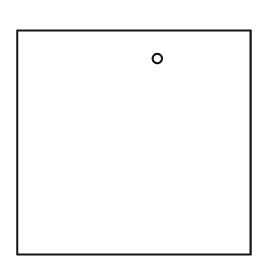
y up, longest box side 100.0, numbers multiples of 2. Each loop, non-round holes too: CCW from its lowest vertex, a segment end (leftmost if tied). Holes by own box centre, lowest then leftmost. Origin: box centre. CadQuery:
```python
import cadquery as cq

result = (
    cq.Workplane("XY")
    .moveTo(-50.0, -48.0)
    .lineTo(50.0, -48.0)
    .lineTo(50.0, 48.0)
    .lineTo(-50.0, 48.0)
    .close()
    .moveTo(10.0, 36.0)
    .circle(2.0)
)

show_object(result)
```